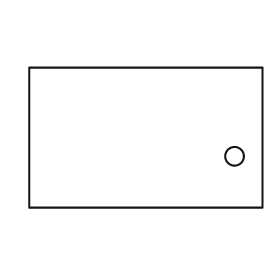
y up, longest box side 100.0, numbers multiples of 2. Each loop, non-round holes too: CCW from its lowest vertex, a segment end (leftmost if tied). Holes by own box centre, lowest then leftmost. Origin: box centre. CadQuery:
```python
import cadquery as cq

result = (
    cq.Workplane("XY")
    .moveTo(-50.0, -30.0)
    .lineTo(50.0, -30.0)
    .lineTo(50.0, 30.0)
    .lineTo(-50.0, 30.0)
    .close()
    .moveTo(38.0, -8.0)
    .circle(4.0)
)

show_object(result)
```